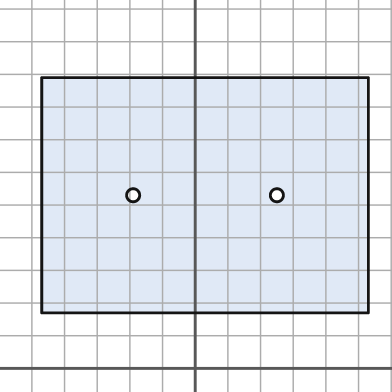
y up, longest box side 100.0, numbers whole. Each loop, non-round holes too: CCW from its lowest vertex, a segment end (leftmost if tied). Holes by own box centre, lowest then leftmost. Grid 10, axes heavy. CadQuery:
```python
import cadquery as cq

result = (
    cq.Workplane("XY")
    .moveTo(-47.0, 17.0)
    .lineTo(53.0, 17.0)
    .lineTo(53.0, 89.0)
    .lineTo(-47.0, 89.0)
    .close()
    .moveTo(-19.0, 53.0)
    .circle(2.0)
    .moveTo(25.0, 53.0)
    .circle(2.0)
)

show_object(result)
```